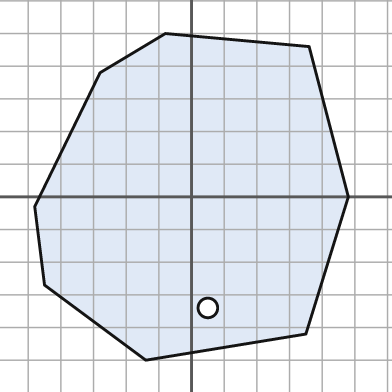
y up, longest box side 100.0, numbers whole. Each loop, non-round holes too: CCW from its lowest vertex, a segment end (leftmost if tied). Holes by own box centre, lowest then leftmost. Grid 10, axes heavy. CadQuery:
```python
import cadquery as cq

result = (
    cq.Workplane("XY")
    .moveTo(-14.0, -50.0)
    .lineTo(35.0, -42.0)
    .lineTo(48.0, 0.0)
    .lineTo(36.0, 46.0)
    .lineTo(-8.0, 50.0)
    .lineTo(-28.0, 38.0)
    .lineTo(-48.0, -3.0)
    .lineTo(-45.0, -27.0)
    .close()
    .moveTo(5.0, -34.0)
    .circle(3.0)
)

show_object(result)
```